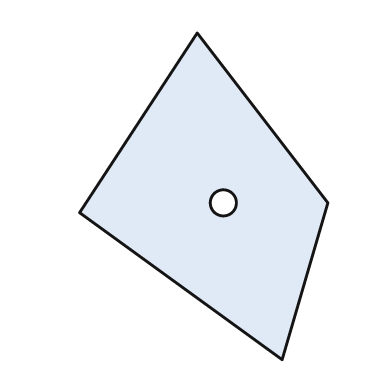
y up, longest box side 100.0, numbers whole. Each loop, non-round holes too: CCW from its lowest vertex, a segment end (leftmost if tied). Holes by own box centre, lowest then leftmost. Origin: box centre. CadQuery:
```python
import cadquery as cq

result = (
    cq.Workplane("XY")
    .moveTo(24.0, -50.0)
    .lineTo(38.0, -2.0)
    .lineTo(-2.0, 50.0)
    .lineTo(-38.0, -5.0)
    .close()
    .moveTo(6.0, -2.0)
    .circle(4.0)
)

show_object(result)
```